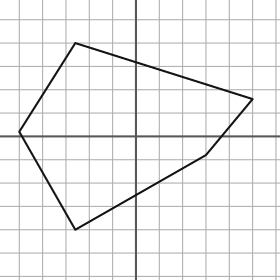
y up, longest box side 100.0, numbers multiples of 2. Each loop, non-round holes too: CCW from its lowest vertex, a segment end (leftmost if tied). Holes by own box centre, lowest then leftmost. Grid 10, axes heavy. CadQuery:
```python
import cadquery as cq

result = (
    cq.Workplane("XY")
    .moveTo(-26.0, -40.0)
    .lineTo(30.0, -8.0)
    .lineTo(50.0, 16.0)
    .lineTo(-26.0, 40.0)
    .lineTo(-50.0, 2.0)
    .close()
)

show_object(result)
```